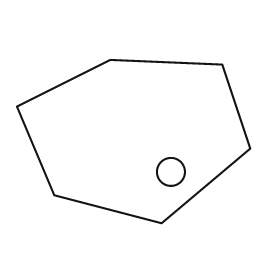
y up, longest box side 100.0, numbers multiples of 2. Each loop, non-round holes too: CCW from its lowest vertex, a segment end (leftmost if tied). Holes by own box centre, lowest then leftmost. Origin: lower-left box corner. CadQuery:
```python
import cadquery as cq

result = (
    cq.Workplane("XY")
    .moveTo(62.0, 0.0)
    .lineTo(100.0, 32.0)
    .lineTo(88.0, 68.0)
    .lineTo(40.0, 70.0)
    .lineTo(0.0, 50.0)
    .lineTo(16.0, 12.0)
    .close()
    .moveTo(66.0, 22.0)
    .circle(6.0)
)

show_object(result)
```